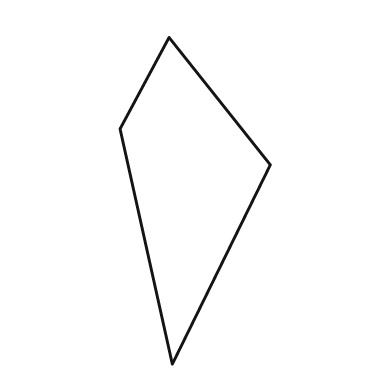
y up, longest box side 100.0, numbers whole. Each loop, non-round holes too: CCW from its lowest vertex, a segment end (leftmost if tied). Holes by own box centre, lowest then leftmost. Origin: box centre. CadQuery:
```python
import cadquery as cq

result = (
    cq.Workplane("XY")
    .moveTo(-7.0, -50.0)
    .lineTo(23.0, 11.0)
    .lineTo(-8.0, 50.0)
    .lineTo(-23.0, 22.0)
    .close()
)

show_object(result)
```